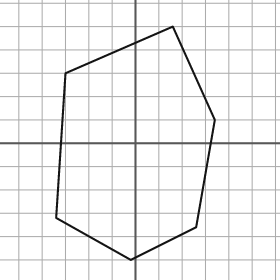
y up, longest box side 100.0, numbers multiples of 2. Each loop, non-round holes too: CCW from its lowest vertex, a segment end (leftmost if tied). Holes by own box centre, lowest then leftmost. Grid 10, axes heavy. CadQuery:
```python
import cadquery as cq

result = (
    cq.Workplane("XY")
    .moveTo(-2.0, -50.0)
    .lineTo(26.0, -36.0)
    .lineTo(34.0, 10.0)
    .lineTo(16.0, 50.0)
    .lineTo(-30.0, 30.0)
    .lineTo(-34.0, -32.0)
    .close()
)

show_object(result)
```